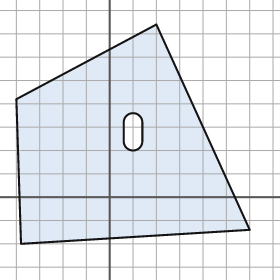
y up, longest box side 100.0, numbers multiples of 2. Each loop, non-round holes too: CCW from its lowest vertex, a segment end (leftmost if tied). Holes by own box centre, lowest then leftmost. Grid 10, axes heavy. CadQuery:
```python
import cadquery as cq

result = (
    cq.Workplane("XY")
    .moveTo(-38.0, -20.0)
    .lineTo(60.0, -14.0)
    .lineTo(20.0, 74.0)
    .lineTo(-40.0, 42.0)
    .close()
    .moveTo(6.0, 24.0)
    .threePointArc((10.0, 20.0), (14.0, 24.0))
    .lineTo(14.0, 32.0)
    .threePointArc((10.0, 36.0), (6.0, 32.0))
    .close()
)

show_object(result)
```